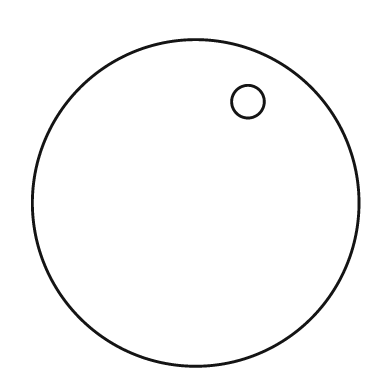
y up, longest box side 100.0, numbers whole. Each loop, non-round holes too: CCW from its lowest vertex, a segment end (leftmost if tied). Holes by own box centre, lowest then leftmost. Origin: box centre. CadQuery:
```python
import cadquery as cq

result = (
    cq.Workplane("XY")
    .moveTo(0.0, 0.0)
    .circle(50.0)
    .moveTo(16.0, 31.0)
    .circle(5.0)
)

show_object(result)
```